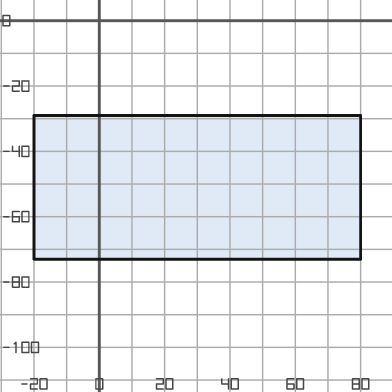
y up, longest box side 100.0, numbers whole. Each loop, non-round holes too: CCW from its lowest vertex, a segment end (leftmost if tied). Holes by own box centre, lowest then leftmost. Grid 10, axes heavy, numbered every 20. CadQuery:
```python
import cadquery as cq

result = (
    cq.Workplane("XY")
    .moveTo(-20.0, -73.0)
    .lineTo(80.0, -73.0)
    .lineTo(80.0, -29.0)
    .lineTo(-20.0, -29.0)
    .close()
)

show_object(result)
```